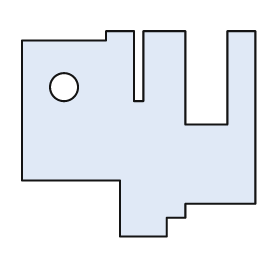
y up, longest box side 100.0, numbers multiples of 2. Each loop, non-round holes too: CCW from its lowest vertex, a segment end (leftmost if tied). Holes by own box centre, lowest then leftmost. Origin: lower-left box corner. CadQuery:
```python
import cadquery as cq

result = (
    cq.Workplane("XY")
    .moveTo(42.0, 0.0)
    .lineTo(62.0, 0.0)
    .lineTo(62.0, 8.0)
    .lineTo(70.0, 8.0)
    .lineTo(70.0, 14.0)
    .lineTo(100.0, 14.0)
    .lineTo(100.0, 88.0)
    .lineTo(88.0, 88.0)
    .lineTo(88.0, 48.0)
    .lineTo(70.0, 48.0)
    .lineTo(70.0, 88.0)
    .lineTo(52.0, 88.0)
    .lineTo(52.0, 58.0)
    .lineTo(48.0, 58.0)
    .lineTo(48.0, 88.0)
    .lineTo(36.0, 88.0)
    .lineTo(36.0, 84.0)
    .lineTo(0.0, 84.0)
    .lineTo(0.0, 24.0)
    .lineTo(42.0, 24.0)
    .close()
    .moveTo(18.0, 64.0)
    .circle(6.0)
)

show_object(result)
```